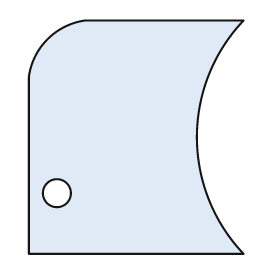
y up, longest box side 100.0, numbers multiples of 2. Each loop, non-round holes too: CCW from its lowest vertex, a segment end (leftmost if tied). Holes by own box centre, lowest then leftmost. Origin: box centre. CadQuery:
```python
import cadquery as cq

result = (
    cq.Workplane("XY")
    .moveTo(-46.0, -50.0)
    .lineTo(46.0, -50.0)
    .threePointArc((26.0, 0.0), (46.0, 50.0))
    .lineTo(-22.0, 50.0)
    .threePointArc((-38.0, 42.0), (-46.0, 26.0))
    .close()
    .moveTo(-34.0, -24.0)
    .circle(6.0)
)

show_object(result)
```